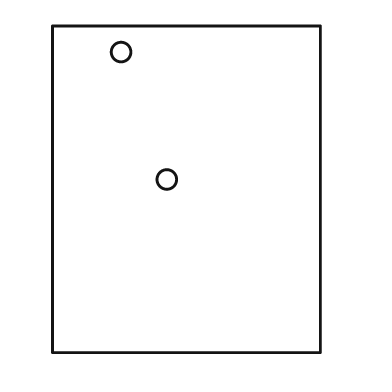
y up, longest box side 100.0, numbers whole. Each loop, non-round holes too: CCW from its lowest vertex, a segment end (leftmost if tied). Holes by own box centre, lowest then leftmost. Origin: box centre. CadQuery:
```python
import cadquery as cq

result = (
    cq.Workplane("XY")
    .moveTo(-41.0, -50.0)
    .lineTo(41.0, -50.0)
    .lineTo(41.0, 50.0)
    .lineTo(-41.0, 50.0)
    .close()
    .moveTo(-6.0, 3.0)
    .circle(3.0)
    .moveTo(-20.0, 42.0)
    .circle(3.0)
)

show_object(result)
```